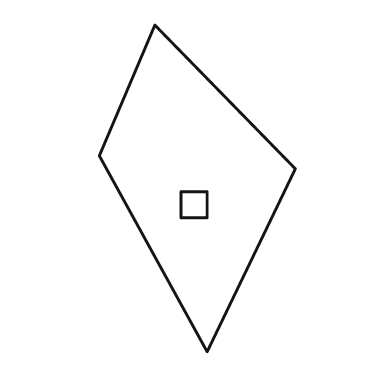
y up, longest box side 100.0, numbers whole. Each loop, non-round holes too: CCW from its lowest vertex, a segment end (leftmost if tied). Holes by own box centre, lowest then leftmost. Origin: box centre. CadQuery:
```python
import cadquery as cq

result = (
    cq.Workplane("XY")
    .moveTo(3.0, -50.0)
    .lineTo(30.0, 6.0)
    .lineTo(-13.0, 50.0)
    .lineTo(-30.0, 10.0)
    .close()
    .moveTo(-5.0, -9.0)
    .lineTo(3.0, -9.0)
    .lineTo(3.0, -1.0)
    .lineTo(-5.0, -1.0)
    .close()
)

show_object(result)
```